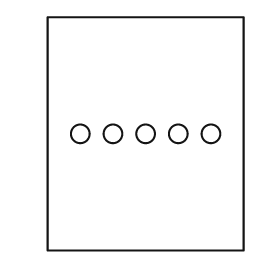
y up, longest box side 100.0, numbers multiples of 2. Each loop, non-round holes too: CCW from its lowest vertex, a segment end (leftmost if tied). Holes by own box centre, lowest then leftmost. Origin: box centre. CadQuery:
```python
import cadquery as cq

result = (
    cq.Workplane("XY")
    .moveTo(-42.0, -50.0)
    .lineTo(42.0, -50.0)
    .lineTo(42.0, 50.0)
    .lineTo(-42.0, 50.0)
    .close()
    .moveTo(-28.0, 0.0)
    .circle(4.0)
    .moveTo(-14.0, 0.0)
    .circle(4.0)
    .moveTo(0.0, 0.0)
    .circle(4.0)
    .moveTo(14.0, 0.0)
    .circle(4.0)
    .moveTo(28.0, 0.0)
    .circle(4.0)
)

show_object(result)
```